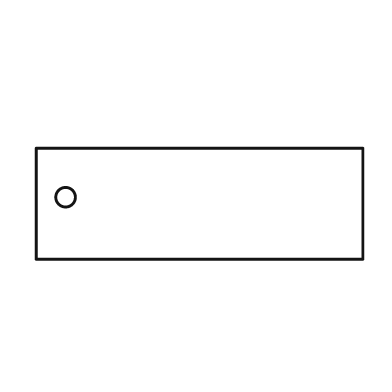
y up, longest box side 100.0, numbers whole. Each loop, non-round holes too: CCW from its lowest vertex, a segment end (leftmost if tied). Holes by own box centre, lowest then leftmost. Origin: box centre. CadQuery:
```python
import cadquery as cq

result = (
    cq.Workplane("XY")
    .moveTo(-50.0, -17.0)
    .lineTo(50.0, -17.0)
    .lineTo(50.0, 17.0)
    .lineTo(-50.0, 17.0)
    .close()
    .moveTo(-41.0, 2.0)
    .circle(3.0)
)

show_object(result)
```